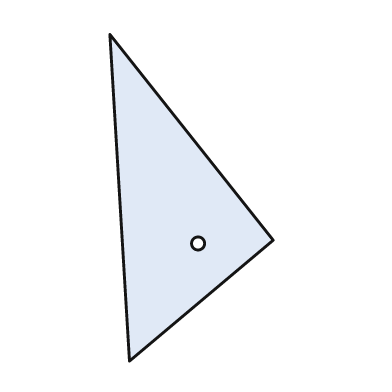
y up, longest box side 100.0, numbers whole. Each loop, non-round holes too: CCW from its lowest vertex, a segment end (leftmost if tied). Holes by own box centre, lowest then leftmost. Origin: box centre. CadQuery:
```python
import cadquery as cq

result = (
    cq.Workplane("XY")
    .moveTo(-19.0, -50.0)
    .lineTo(25.0, -13.0)
    .lineTo(-25.0, 50.0)
    .close()
    .moveTo(2.0, -14.0)
    .circle(2.0)
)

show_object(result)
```